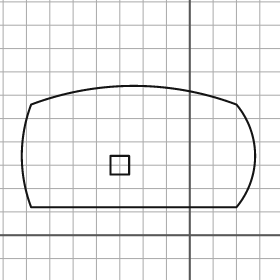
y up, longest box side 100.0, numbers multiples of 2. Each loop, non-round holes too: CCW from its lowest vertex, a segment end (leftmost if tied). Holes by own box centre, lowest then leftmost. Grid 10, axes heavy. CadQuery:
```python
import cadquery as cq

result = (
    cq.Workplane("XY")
    .moveTo(-68.0, 12.0)
    .lineTo(20.0, 12.0)
    .threePointArc((28.0, 34.0), (20.0, 56.0))
    .threePointArc((-24.0, 64.0), (-68.0, 56.0))
    .threePointArc((-72.0, 34.0), (-68.0, 12.0))
    .close()
    .moveTo(-34.0, 26.0)
    .lineTo(-26.0, 26.0)
    .lineTo(-26.0, 34.0)
    .lineTo(-34.0, 34.0)
    .close()
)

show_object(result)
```